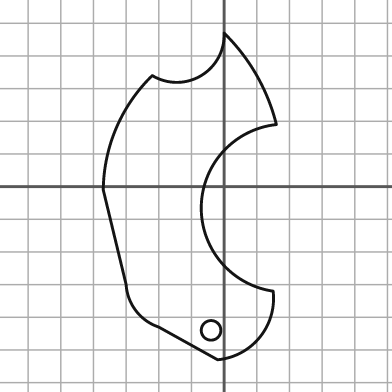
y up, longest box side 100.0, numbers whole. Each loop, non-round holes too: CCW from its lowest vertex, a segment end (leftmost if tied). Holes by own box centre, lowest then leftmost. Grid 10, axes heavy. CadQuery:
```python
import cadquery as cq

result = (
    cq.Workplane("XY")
    .moveTo(-2.0, -53.0)
    .threePointArc((11.0, -46.0), (15.0, -32.0))
    .threePointArc((-7.0, -6.0), (16.0, 19.0))
    .threePointArc((10.0, 34.0), (0.0, 47.0))
    .threePointArc((-7.0, 34.0), (-22.0, 34.0))
    .threePointArc((-33.0, 18.0), (-37.0, -1.0))
    .lineTo(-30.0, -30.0)
    .threePointArc((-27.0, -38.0), (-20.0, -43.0))
    .close()
    .moveTo(-4.0, -44.0)
    .circle(3.0)
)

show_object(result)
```